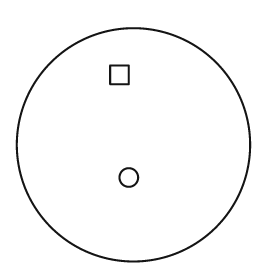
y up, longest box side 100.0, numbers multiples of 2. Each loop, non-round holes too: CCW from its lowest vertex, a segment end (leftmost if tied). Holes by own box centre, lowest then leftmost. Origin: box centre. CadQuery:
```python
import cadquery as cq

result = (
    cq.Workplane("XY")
    .moveTo(0.0, 0.0)
    .circle(50.0)
    .moveTo(-2.0, -14.0)
    .circle(4.0)
    .moveTo(-10.0, 26.0)
    .lineTo(-2.0, 26.0)
    .lineTo(-2.0, 34.0)
    .lineTo(-10.0, 34.0)
    .close()
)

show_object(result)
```